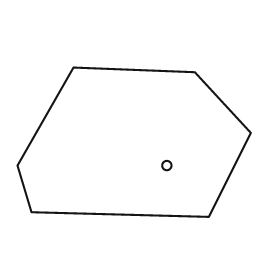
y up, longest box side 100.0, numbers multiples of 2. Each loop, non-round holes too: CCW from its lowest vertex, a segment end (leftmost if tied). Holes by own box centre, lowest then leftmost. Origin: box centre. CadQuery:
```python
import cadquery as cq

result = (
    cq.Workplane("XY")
    .moveTo(32.0, -32.0)
    .lineTo(50.0, 4.0)
    .lineTo(26.0, 30.0)
    .lineTo(-26.0, 32.0)
    .lineTo(-50.0, -10.0)
    .lineTo(-44.0, -30.0)
    .close()
    .moveTo(14.0, -10.0)
    .circle(2.0)
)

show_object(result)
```